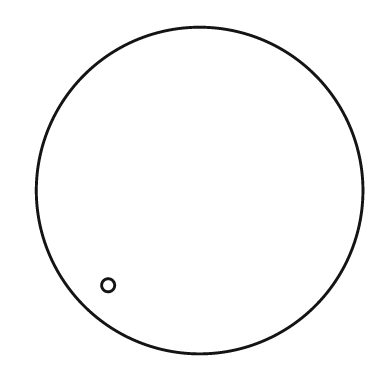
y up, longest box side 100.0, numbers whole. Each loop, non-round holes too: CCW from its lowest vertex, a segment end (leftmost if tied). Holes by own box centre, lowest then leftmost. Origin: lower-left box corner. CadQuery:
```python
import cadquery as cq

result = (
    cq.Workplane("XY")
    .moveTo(50.0, 50.0)
    .circle(50.0)
    .moveTo(22.0, 21.0)
    .circle(2.0)
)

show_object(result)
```